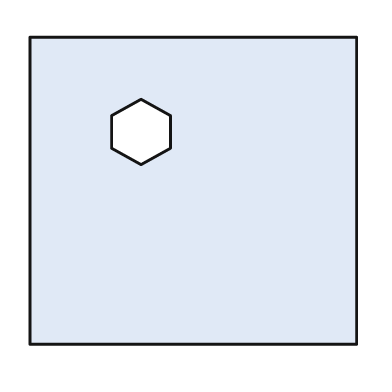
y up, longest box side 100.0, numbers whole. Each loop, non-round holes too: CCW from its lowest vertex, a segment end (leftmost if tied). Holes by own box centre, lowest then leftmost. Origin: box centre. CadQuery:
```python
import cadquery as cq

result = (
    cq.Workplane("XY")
    .moveTo(-50.0, -47.0)
    .lineTo(50.0, -47.0)
    .lineTo(50.0, 47.0)
    .lineTo(-50.0, 47.0)
    .close()
    .moveTo(-16.0, 8.0)
    .lineTo(-7.0, 13.0)
    .lineTo(-7.0, 23.0)
    .lineTo(-16.0, 28.0)
    .lineTo(-25.0, 23.0)
    .lineTo(-25.0, 13.0)
    .close()
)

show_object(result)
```